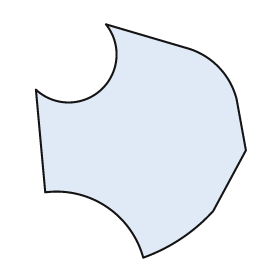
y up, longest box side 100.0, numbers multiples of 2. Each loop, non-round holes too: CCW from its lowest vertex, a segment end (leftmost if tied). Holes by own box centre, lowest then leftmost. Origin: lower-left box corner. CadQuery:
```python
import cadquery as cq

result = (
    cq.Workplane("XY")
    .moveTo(46.0, 0.0)
    .threePointArc((62.0, 8.0), (76.0, 20.0))
    .lineTo(90.0, 46.0)
    .lineTo(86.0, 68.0)
    .threePointArc((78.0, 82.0), (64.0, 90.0))
    .lineTo(30.0, 100.0)
    .threePointArc((28.0, 72.0), (0.0, 72.0))
    .lineTo(4.0, 28.0)
    .threePointArc((30.0, 22.0), (46.0, 0.0))
    .close()
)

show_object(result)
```